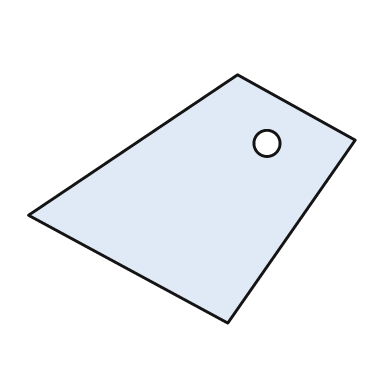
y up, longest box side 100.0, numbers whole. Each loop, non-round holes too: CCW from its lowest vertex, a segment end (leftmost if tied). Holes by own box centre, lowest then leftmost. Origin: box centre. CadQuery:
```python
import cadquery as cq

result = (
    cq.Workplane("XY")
    .moveTo(11.0, -38.0)
    .lineTo(50.0, 18.0)
    .lineTo(14.0, 38.0)
    .lineTo(-50.0, -5.0)
    .close()
    .moveTo(23.0, 17.0)
    .circle(4.0)
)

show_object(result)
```